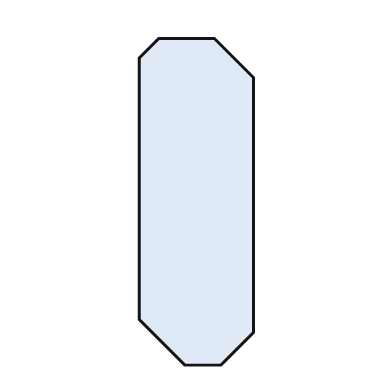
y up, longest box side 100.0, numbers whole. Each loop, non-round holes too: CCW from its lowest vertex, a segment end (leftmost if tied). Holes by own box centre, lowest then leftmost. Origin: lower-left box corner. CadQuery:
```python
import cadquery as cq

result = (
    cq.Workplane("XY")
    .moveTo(14.0, 0.0)
    .lineTo(25.0, 0.0)
    .lineTo(35.0, 10.0)
    .lineTo(35.0, 88.0)
    .lineTo(23.0, 100.0)
    .lineTo(6.0, 100.0)
    .lineTo(0.0, 94.0)
    .lineTo(0.0, 14.0)
    .close()
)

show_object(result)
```